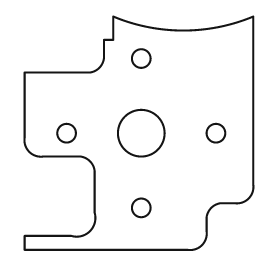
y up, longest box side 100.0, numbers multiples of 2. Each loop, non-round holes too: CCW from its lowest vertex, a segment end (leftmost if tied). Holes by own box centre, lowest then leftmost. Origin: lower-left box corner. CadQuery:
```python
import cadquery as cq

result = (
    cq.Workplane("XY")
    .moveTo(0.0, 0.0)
    .lineTo(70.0, 0.0)
    .threePointArc((76.0, 2.0), (78.0, 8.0))
    .lineTo(78.0, 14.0)
    .threePointArc((80.0, 18.0), (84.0, 20.0))
    .lineTo(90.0, 20.0)
    .threePointArc((96.0, 22.0), (98.0, 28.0))
    .lineTo(98.0, 100.0)
    .threePointArc((68.0, 94.0), (38.0, 100.0))
    .lineTo(38.0, 90.0)
    .lineTo(34.0, 90.0)
    .lineTo(34.0, 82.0)
    .threePointArc((32.0, 78.0), (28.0, 76.0))
    .lineTo(0.0, 76.0)
    .lineTo(0.0, 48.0)
    .threePointArc((2.0, 42.0), (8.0, 40.0))
    .lineTo(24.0, 40.0)
    .threePointArc((28.0, 38.0), (30.0, 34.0))
    .lineTo(30.0, 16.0)
    .threePointArc((28.0, 8.0), (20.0, 6.0))
    .lineTo(0.0, 6.0)
    .close()
    .moveTo(50.0, 18.0)
    .circle(4.0)
    .moveTo(18.0, 50.0)
    .circle(4.0)
    .moveTo(50.0, 50.0)
    .circle(10.0)
    .moveTo(82.0, 50.0)
    .circle(4.0)
    .moveTo(50.0, 82.0)
    .circle(4.0)
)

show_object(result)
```